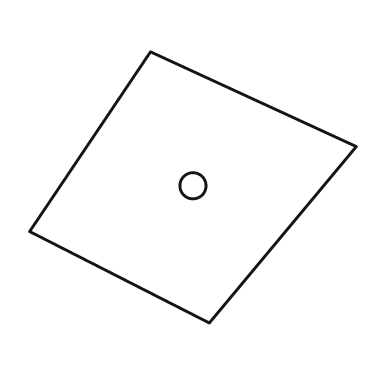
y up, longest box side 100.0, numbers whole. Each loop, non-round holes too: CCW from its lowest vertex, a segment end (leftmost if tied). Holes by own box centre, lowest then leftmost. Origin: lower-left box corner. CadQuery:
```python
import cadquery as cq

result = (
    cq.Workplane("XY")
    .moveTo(55.0, 0.0)
    .lineTo(100.0, 54.0)
    .lineTo(37.0, 83.0)
    .lineTo(0.0, 28.0)
    .close()
    .moveTo(50.0, 42.0)
    .circle(4.0)
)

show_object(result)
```